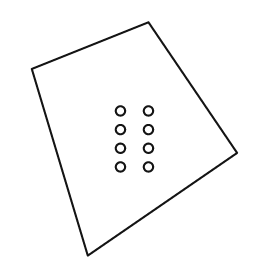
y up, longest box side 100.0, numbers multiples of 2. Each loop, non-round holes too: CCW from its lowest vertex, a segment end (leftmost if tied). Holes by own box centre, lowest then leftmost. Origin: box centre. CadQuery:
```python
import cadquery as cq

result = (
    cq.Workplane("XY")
    .moveTo(-20.0, -50.0)
    .lineTo(44.0, -6.0)
    .lineTo(6.0, 50.0)
    .lineTo(-44.0, 30.0)
    .close()
    .moveTo(-6.0, -12.0)
    .circle(2.0)
    .moveTo(6.0, -12.0)
    .circle(2.0)
    .moveTo(-6.0, -4.0)
    .circle(2.0)
    .moveTo(6.0, -4.0)
    .circle(2.0)
    .moveTo(-6.0, 4.0)
    .circle(2.0)
    .moveTo(6.0, 4.0)
    .circle(2.0)
    .moveTo(-6.0, 12.0)
    .circle(2.0)
    .moveTo(6.0, 12.0)
    .circle(2.0)
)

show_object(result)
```